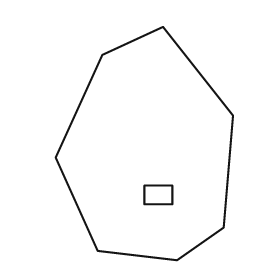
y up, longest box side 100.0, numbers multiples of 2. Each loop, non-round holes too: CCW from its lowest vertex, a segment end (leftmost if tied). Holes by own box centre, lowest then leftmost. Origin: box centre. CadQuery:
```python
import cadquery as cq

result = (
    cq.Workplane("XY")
    .moveTo(14.0, -50.0)
    .lineTo(34.0, -36.0)
    .lineTo(38.0, 12.0)
    .lineTo(8.0, 50.0)
    .lineTo(-18.0, 38.0)
    .lineTo(-38.0, -6.0)
    .lineTo(-20.0, -46.0)
    .close()
    .moveTo(0.0, -26.0)
    .lineTo(12.0, -26.0)
    .lineTo(12.0, -18.0)
    .lineTo(0.0, -18.0)
    .close()
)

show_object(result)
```